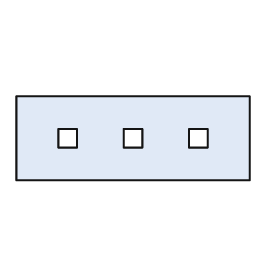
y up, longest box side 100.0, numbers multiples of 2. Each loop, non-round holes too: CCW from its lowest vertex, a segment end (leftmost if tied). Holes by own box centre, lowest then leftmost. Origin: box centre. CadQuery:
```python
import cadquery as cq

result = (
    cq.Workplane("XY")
    .moveTo(-50.0, -18.0)
    .lineTo(50.0, -18.0)
    .lineTo(50.0, 18.0)
    .lineTo(-50.0, 18.0)
    .close()
    .moveTo(-32.0, -4.0)
    .lineTo(-24.0, -4.0)
    .lineTo(-24.0, 4.0)
    .lineTo(-32.0, 4.0)
    .close()
    .moveTo(-4.0, -4.0)
    .lineTo(4.0, -4.0)
    .lineTo(4.0, 4.0)
    .lineTo(-4.0, 4.0)
    .close()
    .moveTo(24.0, -4.0)
    .lineTo(32.0, -4.0)
    .lineTo(32.0, 4.0)
    .lineTo(24.0, 4.0)
    .close()
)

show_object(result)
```